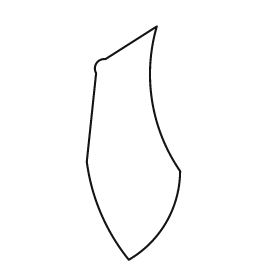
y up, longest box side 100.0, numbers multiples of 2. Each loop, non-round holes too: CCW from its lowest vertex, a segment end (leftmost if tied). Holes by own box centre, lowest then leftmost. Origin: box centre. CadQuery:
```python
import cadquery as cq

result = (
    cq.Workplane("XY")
    .moveTo(-2.0, -50.0)
    .threePointArc((14.0, -34.0), (20.0, -12.0))
    .threePointArc((8.0, 18.0), (10.0, 50.0))
    .lineTo(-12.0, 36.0)
    .threePointArc((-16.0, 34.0), (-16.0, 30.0))
    .lineTo(-20.0, -8.0)
    .threePointArc((-14.0, -30.0), (-2.0, -50.0))
    .close()
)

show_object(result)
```